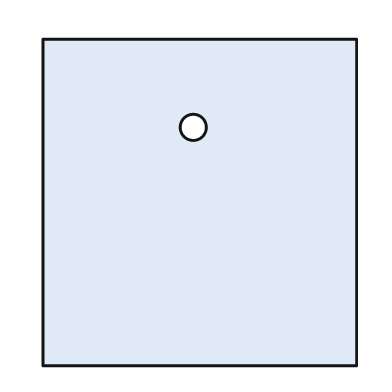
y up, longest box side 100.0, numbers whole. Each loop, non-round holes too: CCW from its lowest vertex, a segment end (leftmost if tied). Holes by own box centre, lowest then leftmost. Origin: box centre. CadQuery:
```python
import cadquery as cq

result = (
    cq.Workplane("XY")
    .moveTo(-48.0, -50.0)
    .lineTo(48.0, -50.0)
    .lineTo(48.0, 50.0)
    .lineTo(-48.0, 50.0)
    .close()
    .moveTo(-2.0, 23.0)
    .circle(4.0)
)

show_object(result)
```